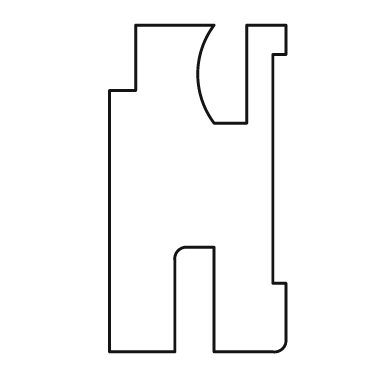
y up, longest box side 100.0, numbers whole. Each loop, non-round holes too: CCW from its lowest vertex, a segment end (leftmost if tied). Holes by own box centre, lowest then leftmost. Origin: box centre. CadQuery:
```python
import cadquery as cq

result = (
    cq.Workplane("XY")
    .moveTo(-27.0, -50.0)
    .lineTo(-7.0, -50.0)
    .lineTo(-7.0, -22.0)
    .threePointArc((-6.0, -19.0), (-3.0, -18.0))
    .lineTo(5.0, -18.0)
    .lineTo(5.0, -50.0)
    .lineTo(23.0, -50.0)
    .threePointArc((26.0, -49.0), (27.0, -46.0))
    .lineTo(27.0, -29.0)
    .lineTo(23.0, -29.0)
    .lineTo(23.0, 41.0)
    .lineTo(27.0, 41.0)
    .lineTo(27.0, 50.0)
    .lineTo(15.0, 50.0)
    .lineTo(15.0, 20.0)
    .lineTo(5.0, 20.0)
    .threePointArc((0.0, 35.0), (5.0, 50.0))
    .lineTo(-19.0, 50.0)
    .lineTo(-19.0, 30.0)
    .lineTo(-27.0, 30.0)
    .close()
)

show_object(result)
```